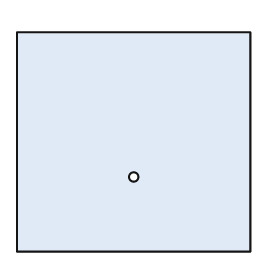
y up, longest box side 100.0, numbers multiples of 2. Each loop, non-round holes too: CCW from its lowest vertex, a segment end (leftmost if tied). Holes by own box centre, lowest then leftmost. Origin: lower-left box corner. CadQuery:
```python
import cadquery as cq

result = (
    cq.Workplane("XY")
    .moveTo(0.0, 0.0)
    .lineTo(100.0, 0.0)
    .lineTo(100.0, 94.0)
    .lineTo(0.0, 94.0)
    .close()
    .moveTo(50.0, 32.0)
    .circle(2.0)
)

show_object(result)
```